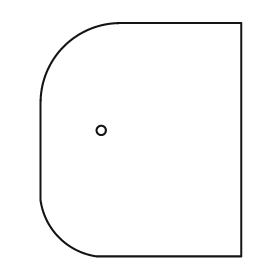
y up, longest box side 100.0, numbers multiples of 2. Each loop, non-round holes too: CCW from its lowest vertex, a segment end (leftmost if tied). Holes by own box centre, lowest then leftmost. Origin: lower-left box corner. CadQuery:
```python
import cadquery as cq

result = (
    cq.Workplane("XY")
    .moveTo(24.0, 0.0)
    .lineTo(86.0, 0.0)
    .lineTo(86.0, 100.0)
    .lineTo(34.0, 100.0)
    .threePointArc((10.0, 90.0), (0.0, 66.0))
    .lineTo(0.0, 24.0)
    .threePointArc((8.0, 8.0), (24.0, 0.0))
    .close()
    .moveTo(26.0, 54.0)
    .circle(2.0)
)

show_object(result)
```